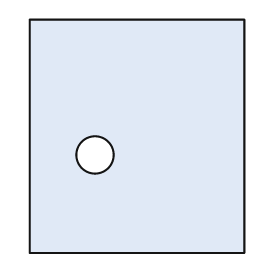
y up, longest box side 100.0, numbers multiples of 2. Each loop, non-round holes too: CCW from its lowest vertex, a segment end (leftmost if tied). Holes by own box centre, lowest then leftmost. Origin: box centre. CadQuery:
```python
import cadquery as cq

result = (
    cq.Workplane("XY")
    .moveTo(-46.0, -50.0)
    .lineTo(46.0, -50.0)
    .lineTo(46.0, 50.0)
    .lineTo(-46.0, 50.0)
    .close()
    .moveTo(-18.0, -8.0)
    .circle(8.0)
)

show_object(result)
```